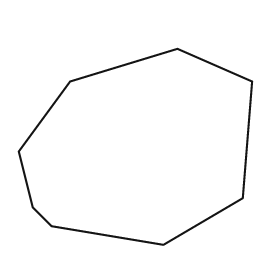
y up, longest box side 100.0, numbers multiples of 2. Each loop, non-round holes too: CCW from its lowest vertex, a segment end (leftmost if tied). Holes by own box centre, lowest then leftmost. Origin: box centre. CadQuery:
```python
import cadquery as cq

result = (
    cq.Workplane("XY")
    .moveTo(12.0, -42.0)
    .lineTo(46.0, -22.0)
    .lineTo(50.0, 28.0)
    .lineTo(18.0, 42.0)
    .lineTo(-28.0, 28.0)
    .lineTo(-50.0, -2.0)
    .lineTo(-44.0, -26.0)
    .lineTo(-36.0, -34.0)
    .close()
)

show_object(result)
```